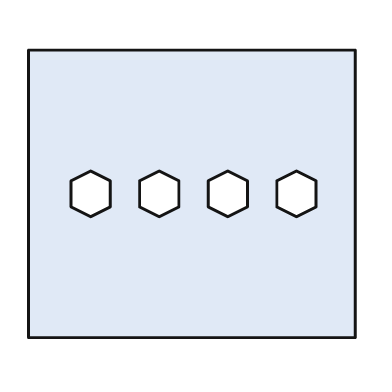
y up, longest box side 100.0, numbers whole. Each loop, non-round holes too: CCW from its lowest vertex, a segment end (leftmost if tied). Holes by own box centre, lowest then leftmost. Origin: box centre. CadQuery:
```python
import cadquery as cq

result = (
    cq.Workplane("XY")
    .moveTo(-50.0, -44.0)
    .lineTo(50.0, -44.0)
    .lineTo(50.0, 44.0)
    .lineTo(-50.0, 44.0)
    .close()
    .moveTo(-31.0, -7.0)
    .lineTo(-25.0, -4.0)
    .lineTo(-25.0, 4.0)
    .lineTo(-31.0, 7.0)
    .lineTo(-37.0, 4.0)
    .lineTo(-37.0, -4.0)
    .close()
    .moveTo(-10.0, -7.0)
    .lineTo(-4.0, -4.0)
    .lineTo(-4.0, 4.0)
    .lineTo(-10.0, 7.0)
    .lineTo(-16.0, 4.0)
    .lineTo(-16.0, -4.0)
    .close()
    .moveTo(11.0, -7.0)
    .lineTo(17.0, -4.0)
    .lineTo(17.0, 4.0)
    .lineTo(11.0, 7.0)
    .lineTo(5.0, 4.0)
    .lineTo(5.0, -4.0)
    .close()
    .moveTo(32.0, -7.0)
    .lineTo(38.0, -4.0)
    .lineTo(38.0, 4.0)
    .lineTo(32.0, 7.0)
    .lineTo(26.0, 4.0)
    .lineTo(26.0, -4.0)
    .close()
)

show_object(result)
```